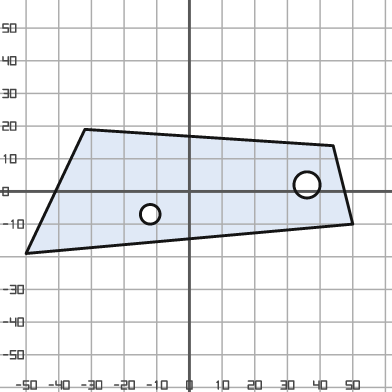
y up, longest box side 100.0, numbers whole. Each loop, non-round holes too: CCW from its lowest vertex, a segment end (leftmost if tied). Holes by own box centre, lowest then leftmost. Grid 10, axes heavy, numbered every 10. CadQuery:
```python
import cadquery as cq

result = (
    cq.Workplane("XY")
    .moveTo(-50.0, -19.0)
    .lineTo(50.0, -10.0)
    .lineTo(44.0, 14.0)
    .lineTo(-32.0, 19.0)
    .close()
    .moveTo(-12.0, -7.0)
    .circle(3.0)
    .moveTo(36.0, 2.0)
    .circle(4.0)
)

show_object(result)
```